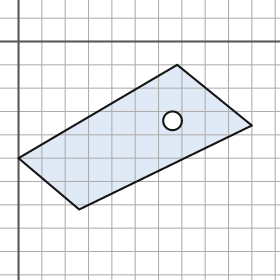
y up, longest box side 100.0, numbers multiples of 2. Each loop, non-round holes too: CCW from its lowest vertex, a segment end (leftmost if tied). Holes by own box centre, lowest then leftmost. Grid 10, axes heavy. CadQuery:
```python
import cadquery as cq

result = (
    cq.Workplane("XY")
    .moveTo(26.0, -72.0)
    .lineTo(100.0, -36.0)
    .lineTo(68.0, -10.0)
    .lineTo(0.0, -50.0)
    .close()
    .moveTo(66.0, -34.0)
    .circle(4.0)
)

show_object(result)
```